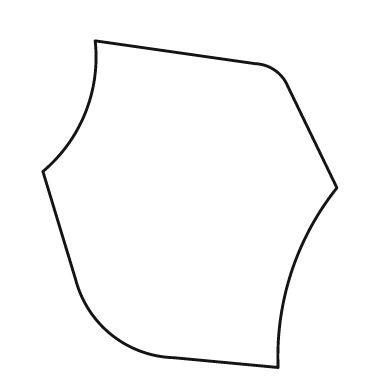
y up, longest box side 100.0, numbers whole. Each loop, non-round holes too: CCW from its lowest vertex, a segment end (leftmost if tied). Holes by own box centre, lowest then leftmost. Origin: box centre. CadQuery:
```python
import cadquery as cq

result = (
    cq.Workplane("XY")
    .moveTo(27.0, -50.0)
    .threePointArc((31.0, -21.0), (45.0, 5.0))
    .lineTo(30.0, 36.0)
    .threePointArc((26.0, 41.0), (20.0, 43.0))
    .lineTo(-29.0, 50.0)
    .threePointArc((-32.0, 28.0), (-45.0, 10.0))
    .lineTo(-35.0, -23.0)
    .threePointArc((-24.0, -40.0), (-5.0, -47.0))
    .close()
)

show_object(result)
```